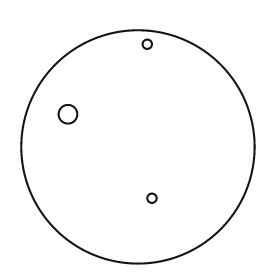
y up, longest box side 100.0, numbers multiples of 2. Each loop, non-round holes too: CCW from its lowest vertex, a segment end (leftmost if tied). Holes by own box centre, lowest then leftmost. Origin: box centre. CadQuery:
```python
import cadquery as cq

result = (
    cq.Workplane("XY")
    .moveTo(0.0, 0.0)
    .circle(50.0)
    .moveTo(6.0, -22.0)
    .circle(2.0)
    .moveTo(-30.0, 14.0)
    .circle(4.0)
    .moveTo(4.0, 44.0)
    .circle(2.0)
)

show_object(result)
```